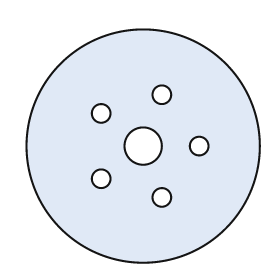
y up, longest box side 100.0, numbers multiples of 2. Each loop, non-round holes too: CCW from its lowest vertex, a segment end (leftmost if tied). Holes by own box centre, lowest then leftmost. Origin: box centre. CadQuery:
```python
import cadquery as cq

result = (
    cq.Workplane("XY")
    .moveTo(0.0, 0.0)
    .circle(50.0)
    .moveTo(8.0, -22.0)
    .circle(4.0)
    .moveTo(-18.0, -14.0)
    .circle(4.0)
    .moveTo(0.0, 0.0)
    .circle(8.0)
    .moveTo(24.0, 0.0)
    .circle(4.0)
    .moveTo(-18.0, 14.0)
    .circle(4.0)
    .moveTo(8.0, 22.0)
    .circle(4.0)
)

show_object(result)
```